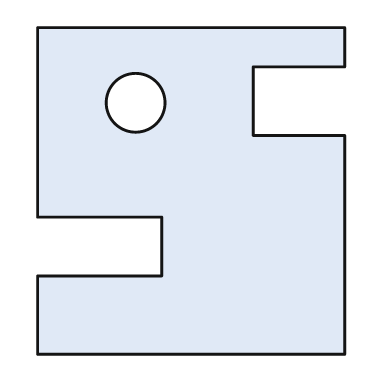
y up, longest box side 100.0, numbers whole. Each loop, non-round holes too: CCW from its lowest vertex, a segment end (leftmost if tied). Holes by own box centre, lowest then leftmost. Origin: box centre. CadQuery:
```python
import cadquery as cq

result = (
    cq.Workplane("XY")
    .moveTo(-47.0, -50.0)
    .lineTo(47.0, -50.0)
    .lineTo(47.0, 17.0)
    .lineTo(19.0, 17.0)
    .lineTo(19.0, 38.0)
    .lineTo(47.0, 38.0)
    .lineTo(47.0, 50.0)
    .lineTo(-47.0, 50.0)
    .lineTo(-47.0, -8.0)
    .lineTo(-9.0, -8.0)
    .lineTo(-9.0, -26.0)
    .lineTo(-47.0, -26.0)
    .close()
    .moveTo(-17.0, 27.0)
    .circle(9.0)
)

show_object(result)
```